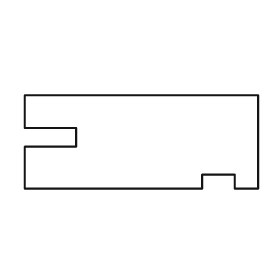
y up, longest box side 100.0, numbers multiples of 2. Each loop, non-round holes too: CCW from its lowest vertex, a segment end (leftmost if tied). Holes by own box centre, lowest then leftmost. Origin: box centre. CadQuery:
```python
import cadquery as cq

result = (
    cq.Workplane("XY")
    .moveTo(-50.0, -20.0)
    .lineTo(26.0, -20.0)
    .lineTo(26.0, -14.0)
    .lineTo(40.0, -14.0)
    .lineTo(40.0, -20.0)
    .lineTo(50.0, -20.0)
    .lineTo(50.0, 20.0)
    .lineTo(-50.0, 20.0)
    .lineTo(-50.0, 6.0)
    .lineTo(-28.0, 6.0)
    .lineTo(-28.0, -2.0)
    .lineTo(-50.0, -2.0)
    .close()
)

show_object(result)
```